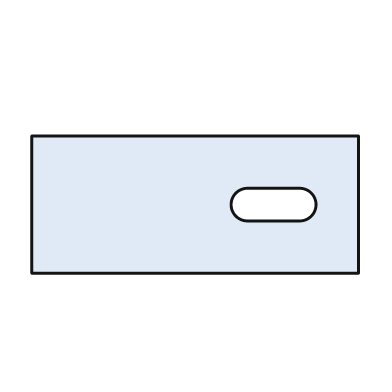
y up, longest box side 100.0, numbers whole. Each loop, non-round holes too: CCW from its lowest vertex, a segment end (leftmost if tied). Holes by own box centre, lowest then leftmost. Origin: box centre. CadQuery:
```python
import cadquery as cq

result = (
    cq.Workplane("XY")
    .moveTo(-50.0, -21.0)
    .lineTo(50.0, -21.0)
    .lineTo(50.0, 21.0)
    .lineTo(-50.0, 21.0)
    .close()
    .moveTo(16.0, -5.0)
    .lineTo(32.0, -5.0)
    .threePointArc((37.0, 0.0), (32.0, 5.0))
    .lineTo(16.0, 5.0)
    .threePointArc((11.0, 0.0), (16.0, -5.0))
    .close()
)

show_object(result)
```